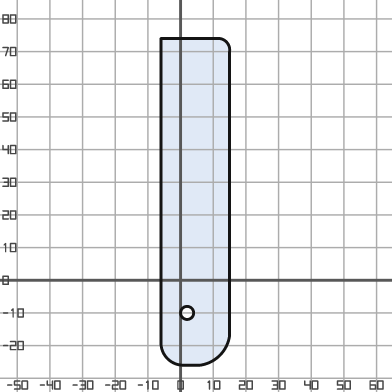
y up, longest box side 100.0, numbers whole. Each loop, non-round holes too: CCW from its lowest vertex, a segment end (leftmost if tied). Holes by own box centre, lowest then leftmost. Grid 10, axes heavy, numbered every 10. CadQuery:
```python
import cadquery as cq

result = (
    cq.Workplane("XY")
    .moveTo(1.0, -26.0)
    .lineTo(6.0, -26.0)
    .threePointArc((12.0, -23.0), (15.0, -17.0))
    .lineTo(15.0, 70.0)
    .threePointArc((14.0, 73.0), (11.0, 74.0))
    .lineTo(-6.0, 74.0)
    .lineTo(-6.0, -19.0)
    .threePointArc((-4.0, -24.0), (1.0, -26.0))
    .close()
    .moveTo(2.0, -10.0)
    .circle(2.0)
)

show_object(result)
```